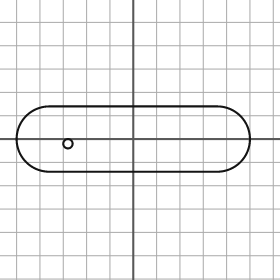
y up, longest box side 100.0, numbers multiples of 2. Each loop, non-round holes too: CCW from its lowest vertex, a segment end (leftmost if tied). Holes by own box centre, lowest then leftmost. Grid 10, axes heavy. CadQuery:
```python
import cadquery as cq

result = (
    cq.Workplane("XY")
    .moveTo(-36.0, -14.0)
    .lineTo(36.0, -14.0)
    .threePointArc((50.0, 0.0), (36.0, 14.0))
    .lineTo(-36.0, 14.0)
    .threePointArc((-50.0, 0.0), (-36.0, -14.0))
    .close()
    .moveTo(-28.0, -2.0)
    .circle(2.0)
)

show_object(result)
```